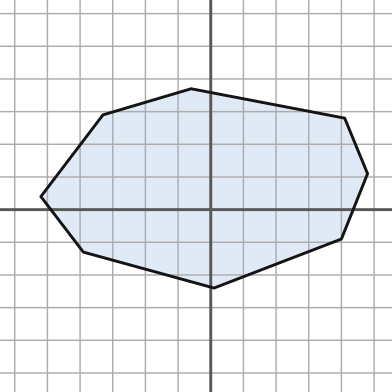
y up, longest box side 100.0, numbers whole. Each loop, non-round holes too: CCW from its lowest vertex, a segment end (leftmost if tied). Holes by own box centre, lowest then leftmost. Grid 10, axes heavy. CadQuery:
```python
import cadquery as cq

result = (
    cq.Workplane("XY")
    .moveTo(1.0, -24.0)
    .lineTo(40.0, -9.0)
    .lineTo(48.0, 11.0)
    .lineTo(41.0, 28.0)
    .lineTo(-6.0, 37.0)
    .lineTo(-33.0, 29.0)
    .lineTo(-52.0, 4.0)
    .lineTo(-39.0, -13.0)
    .close()
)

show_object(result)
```